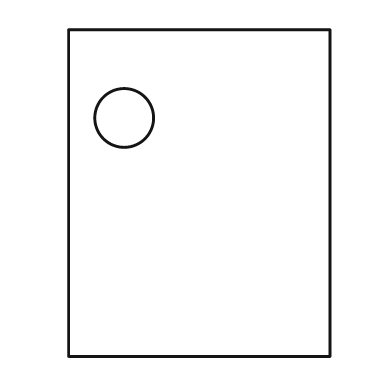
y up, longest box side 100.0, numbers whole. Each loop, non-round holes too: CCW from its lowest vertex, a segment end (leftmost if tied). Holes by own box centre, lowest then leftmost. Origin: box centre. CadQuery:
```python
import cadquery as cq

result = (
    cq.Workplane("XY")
    .moveTo(-40.0, -50.0)
    .lineTo(40.0, -50.0)
    .lineTo(40.0, 50.0)
    .lineTo(-40.0, 50.0)
    .close()
    .moveTo(-23.0, 23.0)
    .circle(9.0)
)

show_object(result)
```